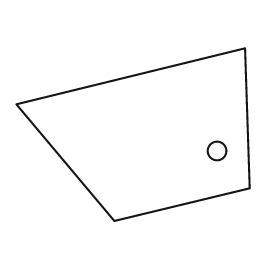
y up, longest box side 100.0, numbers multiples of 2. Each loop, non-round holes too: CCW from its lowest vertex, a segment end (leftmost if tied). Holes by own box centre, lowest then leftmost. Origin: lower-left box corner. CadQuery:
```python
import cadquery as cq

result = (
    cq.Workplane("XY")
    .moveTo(42.0, 0.0)
    .lineTo(100.0, 14.0)
    .lineTo(98.0, 74.0)
    .lineTo(0.0, 50.0)
    .close()
    .moveTo(86.0, 30.0)
    .circle(4.0)
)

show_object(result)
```